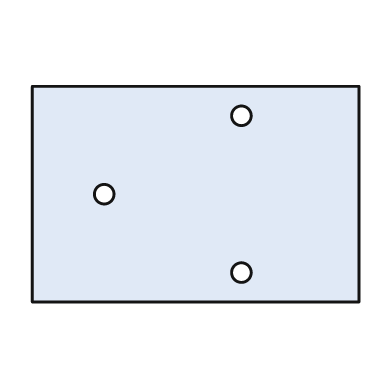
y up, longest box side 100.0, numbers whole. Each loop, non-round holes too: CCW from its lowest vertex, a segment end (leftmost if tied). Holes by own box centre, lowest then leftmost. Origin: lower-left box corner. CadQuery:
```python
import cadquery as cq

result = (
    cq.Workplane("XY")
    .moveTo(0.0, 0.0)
    .lineTo(100.0, 0.0)
    .lineTo(100.0, 66.0)
    .lineTo(0.0, 66.0)
    .close()
    .moveTo(64.0, 9.0)
    .circle(3.0)
    .moveTo(22.0, 33.0)
    .circle(3.0)
    .moveTo(64.0, 57.0)
    .circle(3.0)
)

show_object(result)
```